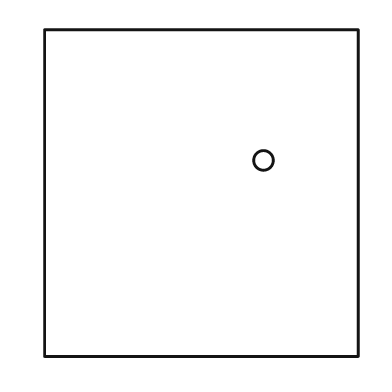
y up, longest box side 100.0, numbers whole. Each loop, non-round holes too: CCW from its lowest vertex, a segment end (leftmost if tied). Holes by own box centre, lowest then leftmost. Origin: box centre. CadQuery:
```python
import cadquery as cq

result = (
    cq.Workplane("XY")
    .moveTo(-48.0, -50.0)
    .lineTo(48.0, -50.0)
    .lineTo(48.0, 50.0)
    .lineTo(-48.0, 50.0)
    .close()
    .moveTo(19.0, 10.0)
    .circle(3.0)
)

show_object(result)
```